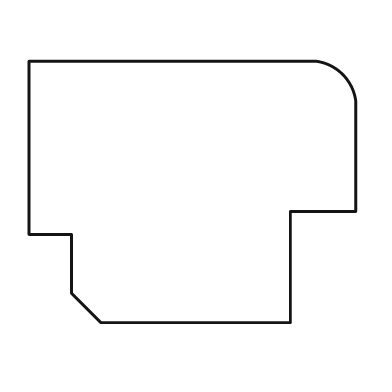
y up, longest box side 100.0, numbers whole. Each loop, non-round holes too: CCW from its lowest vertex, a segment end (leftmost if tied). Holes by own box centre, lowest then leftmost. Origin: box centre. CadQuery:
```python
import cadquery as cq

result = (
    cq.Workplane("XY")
    .moveTo(-28.0, -40.0)
    .lineTo(30.0, -40.0)
    .lineTo(30.0, -6.0)
    .lineTo(50.0, -6.0)
    .lineTo(50.0, 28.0)
    .threePointArc((46.0, 36.0), (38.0, 40.0))
    .lineTo(-50.0, 40.0)
    .lineTo(-50.0, -13.0)
    .lineTo(-37.0, -13.0)
    .lineTo(-37.0, -31.0)
    .close()
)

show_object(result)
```